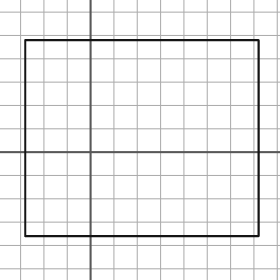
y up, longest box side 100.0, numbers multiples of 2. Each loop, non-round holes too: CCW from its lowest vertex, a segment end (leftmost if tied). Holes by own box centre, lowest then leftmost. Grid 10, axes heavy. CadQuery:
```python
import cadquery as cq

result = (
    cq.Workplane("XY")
    .moveTo(-28.0, -36.0)
    .lineTo(72.0, -36.0)
    .lineTo(72.0, 48.0)
    .lineTo(-28.0, 48.0)
    .close()
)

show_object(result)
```